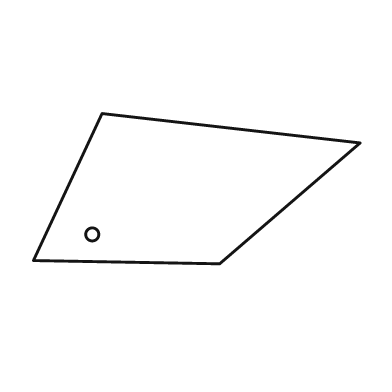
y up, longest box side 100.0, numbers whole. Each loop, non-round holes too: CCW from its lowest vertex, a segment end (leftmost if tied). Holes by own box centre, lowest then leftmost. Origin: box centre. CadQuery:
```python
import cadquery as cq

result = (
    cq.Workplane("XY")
    .moveTo(7.0, -23.0)
    .lineTo(50.0, 14.0)
    .lineTo(-29.0, 23.0)
    .lineTo(-50.0, -22.0)
    .close()
    .moveTo(-32.0, -14.0)
    .circle(2.0)
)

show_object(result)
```